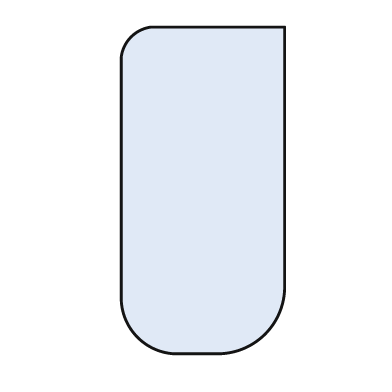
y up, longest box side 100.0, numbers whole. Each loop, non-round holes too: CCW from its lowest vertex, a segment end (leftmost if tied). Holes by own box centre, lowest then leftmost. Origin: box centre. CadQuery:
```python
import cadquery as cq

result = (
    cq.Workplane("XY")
    .moveTo(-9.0, -50.0)
    .lineTo(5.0, -50.0)
    .threePointArc((19.0, -44.0), (25.0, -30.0))
    .lineTo(25.0, 50.0)
    .lineTo(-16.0, 50.0)
    .threePointArc((-22.0, 47.0), (-25.0, 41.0))
    .lineTo(-25.0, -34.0)
    .threePointArc((-20.0, -45.0), (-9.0, -50.0))
    .close()
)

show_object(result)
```